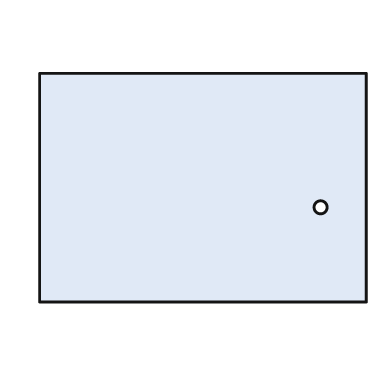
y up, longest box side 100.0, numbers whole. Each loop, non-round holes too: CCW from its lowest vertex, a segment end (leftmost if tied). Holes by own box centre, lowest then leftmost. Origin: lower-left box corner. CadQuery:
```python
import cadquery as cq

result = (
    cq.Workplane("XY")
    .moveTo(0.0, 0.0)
    .lineTo(100.0, 0.0)
    .lineTo(100.0, 70.0)
    .lineTo(0.0, 70.0)
    .close()
    .moveTo(86.0, 29.0)
    .circle(2.0)
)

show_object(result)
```